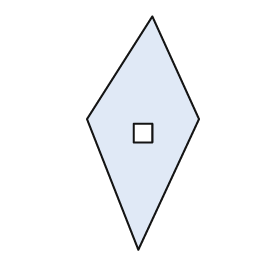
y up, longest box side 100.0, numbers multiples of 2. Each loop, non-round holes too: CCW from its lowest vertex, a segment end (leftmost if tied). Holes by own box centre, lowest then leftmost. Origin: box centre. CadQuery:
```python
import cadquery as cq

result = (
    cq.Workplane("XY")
    .moveTo(-2.0, -50.0)
    .lineTo(24.0, 6.0)
    .lineTo(4.0, 50.0)
    .lineTo(-24.0, 6.0)
    .close()
    .moveTo(-4.0, -4.0)
    .lineTo(4.0, -4.0)
    .lineTo(4.0, 4.0)
    .lineTo(-4.0, 4.0)
    .close()
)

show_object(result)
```